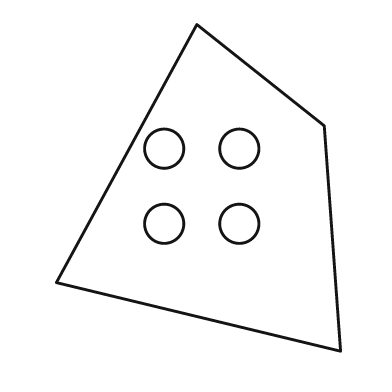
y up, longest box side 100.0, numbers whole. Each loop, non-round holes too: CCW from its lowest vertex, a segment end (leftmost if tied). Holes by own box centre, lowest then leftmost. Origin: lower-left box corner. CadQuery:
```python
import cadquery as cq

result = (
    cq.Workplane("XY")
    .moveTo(87.0, 0.0)
    .lineTo(82.0, 69.0)
    .lineTo(43.0, 100.0)
    .lineTo(0.0, 21.0)
    .close()
    .moveTo(33.0, 39.0)
    .circle(6.0)
    .moveTo(56.0, 39.0)
    .circle(6.0)
    .moveTo(33.0, 62.0)
    .circle(6.0)
    .moveTo(56.0, 62.0)
    .circle(6.0)
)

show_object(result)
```